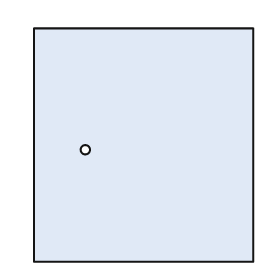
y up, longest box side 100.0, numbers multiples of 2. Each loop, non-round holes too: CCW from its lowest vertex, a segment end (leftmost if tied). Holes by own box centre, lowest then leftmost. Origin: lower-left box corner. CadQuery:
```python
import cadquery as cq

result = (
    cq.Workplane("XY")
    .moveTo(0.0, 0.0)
    .lineTo(94.0, 0.0)
    .lineTo(94.0, 100.0)
    .lineTo(0.0, 100.0)
    .close()
    .moveTo(22.0, 48.0)
    .circle(2.0)
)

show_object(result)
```